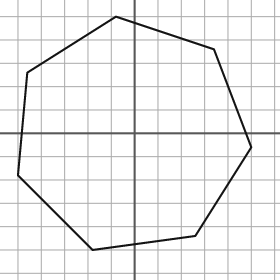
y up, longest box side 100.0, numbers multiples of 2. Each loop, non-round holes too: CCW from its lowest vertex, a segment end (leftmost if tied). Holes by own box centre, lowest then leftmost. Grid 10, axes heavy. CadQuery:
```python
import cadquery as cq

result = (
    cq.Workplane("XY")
    .moveTo(-18.0, -50.0)
    .lineTo(26.0, -44.0)
    .lineTo(50.0, -6.0)
    .lineTo(34.0, 36.0)
    .lineTo(-8.0, 50.0)
    .lineTo(-46.0, 26.0)
    .lineTo(-50.0, -18.0)
    .close()
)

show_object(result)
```